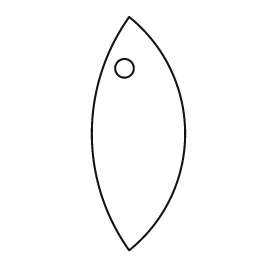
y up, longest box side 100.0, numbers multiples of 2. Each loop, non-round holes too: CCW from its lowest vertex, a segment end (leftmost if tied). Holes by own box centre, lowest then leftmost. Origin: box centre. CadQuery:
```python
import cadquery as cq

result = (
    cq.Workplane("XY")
    .moveTo(-4.0, -50.0)
    .threePointArc((20.0, 0.0), (-4.0, 50.0))
    .threePointArc((-20.0, 0.0), (-4.0, -50.0))
    .close()
    .moveTo(-6.0, 28.0)
    .circle(4.0)
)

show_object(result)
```